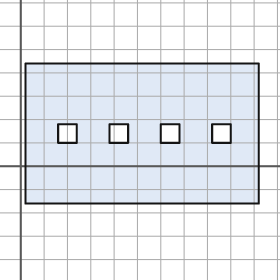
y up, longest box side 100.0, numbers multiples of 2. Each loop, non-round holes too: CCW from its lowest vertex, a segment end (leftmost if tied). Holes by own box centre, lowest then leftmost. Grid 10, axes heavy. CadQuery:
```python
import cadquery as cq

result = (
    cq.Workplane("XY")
    .moveTo(2.0, -16.0)
    .lineTo(102.0, -16.0)
    .lineTo(102.0, 44.0)
    .lineTo(2.0, 44.0)
    .close()
    .moveTo(16.0, 10.0)
    .lineTo(24.0, 10.0)
    .lineTo(24.0, 18.0)
    .lineTo(16.0, 18.0)
    .close()
    .moveTo(38.0, 10.0)
    .lineTo(46.0, 10.0)
    .lineTo(46.0, 18.0)
    .lineTo(38.0, 18.0)
    .close()
    .moveTo(60.0, 10.0)
    .lineTo(68.0, 10.0)
    .lineTo(68.0, 18.0)
    .lineTo(60.0, 18.0)
    .close()
    .moveTo(82.0, 10.0)
    .lineTo(90.0, 10.0)
    .lineTo(90.0, 18.0)
    .lineTo(82.0, 18.0)
    .close()
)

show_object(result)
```